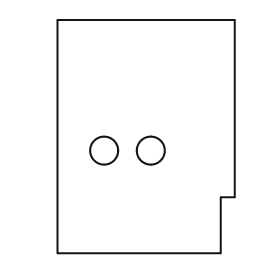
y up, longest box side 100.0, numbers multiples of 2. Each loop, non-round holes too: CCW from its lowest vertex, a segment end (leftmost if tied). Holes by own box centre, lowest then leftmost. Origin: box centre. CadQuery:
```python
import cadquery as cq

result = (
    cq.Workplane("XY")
    .moveTo(-38.0, -50.0)
    .lineTo(32.0, -50.0)
    .lineTo(32.0, -26.0)
    .lineTo(38.0, -26.0)
    .lineTo(38.0, 50.0)
    .lineTo(-38.0, 50.0)
    .close()
    .moveTo(-18.0, -6.0)
    .circle(6.0)
    .moveTo(2.0, -6.0)
    .circle(6.0)
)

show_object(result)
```